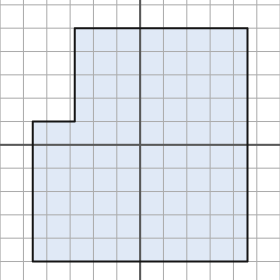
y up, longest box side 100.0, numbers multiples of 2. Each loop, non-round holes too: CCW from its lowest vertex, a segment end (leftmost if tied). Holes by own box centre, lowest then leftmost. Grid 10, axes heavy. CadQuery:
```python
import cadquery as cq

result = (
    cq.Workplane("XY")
    .moveTo(-46.0, -50.0)
    .lineTo(46.0, -50.0)
    .lineTo(46.0, 50.0)
    .lineTo(-28.0, 50.0)
    .lineTo(-28.0, 10.0)
    .lineTo(-46.0, 10.0)
    .close()
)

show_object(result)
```